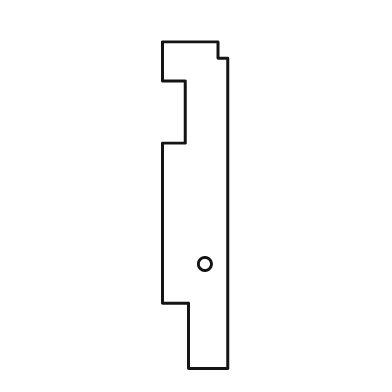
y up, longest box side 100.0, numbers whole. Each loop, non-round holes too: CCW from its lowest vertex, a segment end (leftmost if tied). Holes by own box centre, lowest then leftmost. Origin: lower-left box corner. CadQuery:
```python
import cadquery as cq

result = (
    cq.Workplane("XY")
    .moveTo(8.0, 0.0)
    .lineTo(20.0, 0.0)
    .lineTo(20.0, 95.0)
    .lineTo(17.0, 95.0)
    .lineTo(17.0, 100.0)
    .lineTo(0.0, 100.0)
    .lineTo(0.0, 88.0)
    .lineTo(7.0, 88.0)
    .lineTo(7.0, 69.0)
    .lineTo(0.0, 69.0)
    .lineTo(0.0, 20.0)
    .lineTo(8.0, 20.0)
    .close()
    .moveTo(13.0, 32.0)
    .circle(2.0)
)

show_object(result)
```